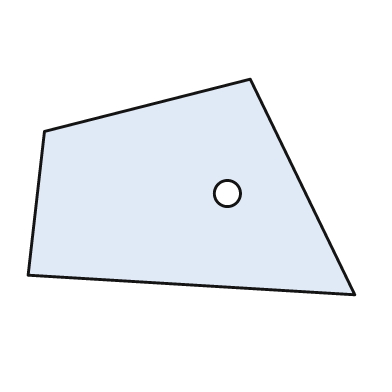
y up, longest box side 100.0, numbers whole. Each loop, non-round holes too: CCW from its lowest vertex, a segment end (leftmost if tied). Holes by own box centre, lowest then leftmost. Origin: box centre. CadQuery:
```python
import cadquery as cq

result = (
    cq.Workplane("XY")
    .moveTo(50.0, -33.0)
    .lineTo(18.0, 33.0)
    .lineTo(-45.0, 17.0)
    .lineTo(-50.0, -27.0)
    .close()
    .moveTo(11.0, -2.0)
    .circle(4.0)
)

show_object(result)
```